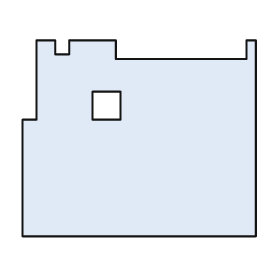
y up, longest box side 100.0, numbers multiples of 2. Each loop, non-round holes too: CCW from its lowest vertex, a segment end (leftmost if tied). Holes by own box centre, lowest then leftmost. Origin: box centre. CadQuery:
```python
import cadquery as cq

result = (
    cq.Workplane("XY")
    .moveTo(-50.0, -42.0)
    .lineTo(50.0, -42.0)
    .lineTo(50.0, 42.0)
    .lineTo(46.0, 42.0)
    .lineTo(46.0, 34.0)
    .lineTo(-10.0, 34.0)
    .lineTo(-10.0, 42.0)
    .lineTo(-30.0, 42.0)
    .lineTo(-30.0, 36.0)
    .lineTo(-36.0, 36.0)
    .lineTo(-36.0, 42.0)
    .lineTo(-44.0, 42.0)
    .lineTo(-44.0, 8.0)
    .lineTo(-50.0, 8.0)
    .close()
    .moveTo(-20.0, 8.0)
    .lineTo(-8.0, 8.0)
    .lineTo(-8.0, 20.0)
    .lineTo(-20.0, 20.0)
    .close()
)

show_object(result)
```